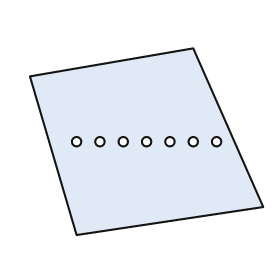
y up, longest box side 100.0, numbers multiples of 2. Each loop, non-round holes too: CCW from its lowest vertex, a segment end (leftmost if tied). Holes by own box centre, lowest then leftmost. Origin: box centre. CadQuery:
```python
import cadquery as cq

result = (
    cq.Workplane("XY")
    .moveTo(-30.0, -40.0)
    .lineTo(50.0, -28.0)
    .lineTo(20.0, 40.0)
    .lineTo(-50.0, 28.0)
    .close()
    .moveTo(-30.0, 0.0)
    .circle(2.0)
    .moveTo(-20.0, 0.0)
    .circle(2.0)
    .moveTo(-10.0, 0.0)
    .circle(2.0)
    .moveTo(0.0, 0.0)
    .circle(2.0)
    .moveTo(10.0, 0.0)
    .circle(2.0)
    .moveTo(20.0, 0.0)
    .circle(2.0)
    .moveTo(30.0, 0.0)
    .circle(2.0)
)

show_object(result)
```